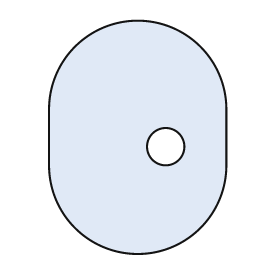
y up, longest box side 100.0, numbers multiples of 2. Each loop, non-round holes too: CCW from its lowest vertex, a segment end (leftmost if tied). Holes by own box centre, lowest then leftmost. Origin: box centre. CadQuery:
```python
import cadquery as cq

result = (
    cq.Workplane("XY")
    .moveTo(-38.0, -12.0)
    .threePointArc((0.0, -50.0), (38.0, -12.0))
    .lineTo(38.0, 12.0)
    .threePointArc((0.0, 50.0), (-38.0, 12.0))
    .close()
    .moveTo(12.0, -4.0)
    .circle(8.0)
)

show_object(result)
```